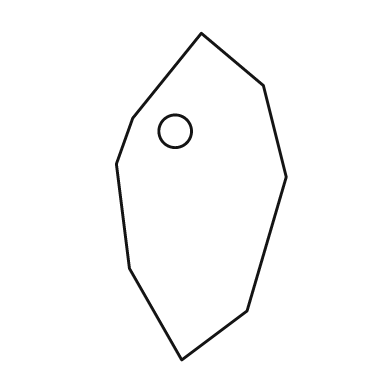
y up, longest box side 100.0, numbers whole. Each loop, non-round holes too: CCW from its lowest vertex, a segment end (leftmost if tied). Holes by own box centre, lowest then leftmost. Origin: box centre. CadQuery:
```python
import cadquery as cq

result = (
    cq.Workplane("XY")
    .moveTo(-6.0, -50.0)
    .lineTo(14.0, -35.0)
    .lineTo(26.0, 6.0)
    .lineTo(19.0, 34.0)
    .lineTo(0.0, 50.0)
    .lineTo(-21.0, 24.0)
    .lineTo(-26.0, 10.0)
    .lineTo(-22.0, -22.0)
    .close()
    .moveTo(-8.0, 20.0)
    .circle(5.0)
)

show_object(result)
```